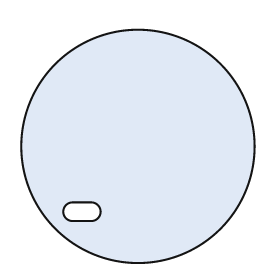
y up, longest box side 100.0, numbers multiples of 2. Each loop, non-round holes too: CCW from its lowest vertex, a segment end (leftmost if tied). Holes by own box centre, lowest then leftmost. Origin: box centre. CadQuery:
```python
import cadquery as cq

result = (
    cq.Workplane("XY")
    .moveTo(0.0, 0.0)
    .circle(50.0)
    .moveTo(-28.0, -32.0)
    .lineTo(-20.0, -32.0)
    .threePointArc((-16.0, -28.0), (-20.0, -24.0))
    .lineTo(-28.0, -24.0)
    .threePointArc((-32.0, -28.0), (-28.0, -32.0))
    .close()
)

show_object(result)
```